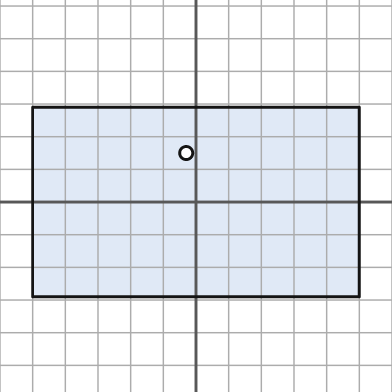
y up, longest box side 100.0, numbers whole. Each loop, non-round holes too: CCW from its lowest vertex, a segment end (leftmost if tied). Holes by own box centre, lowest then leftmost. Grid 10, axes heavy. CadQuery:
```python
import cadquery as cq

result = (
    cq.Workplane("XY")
    .moveTo(-50.0, -29.0)
    .lineTo(50.0, -29.0)
    .lineTo(50.0, 29.0)
    .lineTo(-50.0, 29.0)
    .close()
    .moveTo(-3.0, 15.0)
    .circle(2.0)
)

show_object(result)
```